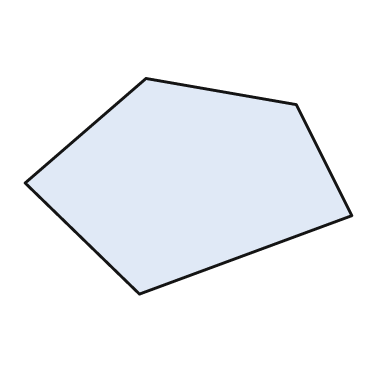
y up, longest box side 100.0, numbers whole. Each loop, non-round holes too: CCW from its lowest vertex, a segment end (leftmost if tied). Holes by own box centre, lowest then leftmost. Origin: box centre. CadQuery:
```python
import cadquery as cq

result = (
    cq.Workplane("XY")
    .moveTo(-15.0, -33.0)
    .lineTo(50.0, -9.0)
    .lineTo(33.0, 25.0)
    .lineTo(-13.0, 33.0)
    .lineTo(-50.0, 1.0)
    .close()
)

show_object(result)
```